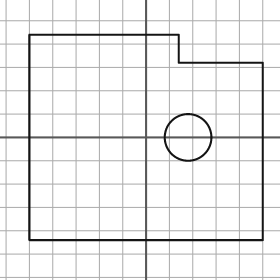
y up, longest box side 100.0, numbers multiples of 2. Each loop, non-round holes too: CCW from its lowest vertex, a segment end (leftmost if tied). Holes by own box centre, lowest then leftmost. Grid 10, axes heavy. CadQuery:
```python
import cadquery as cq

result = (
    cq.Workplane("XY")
    .moveTo(-50.0, -44.0)
    .lineTo(50.0, -44.0)
    .lineTo(50.0, 32.0)
    .lineTo(14.0, 32.0)
    .lineTo(14.0, 44.0)
    .lineTo(-50.0, 44.0)
    .close()
    .moveTo(18.0, 0.0)
    .circle(10.0)
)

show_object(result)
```